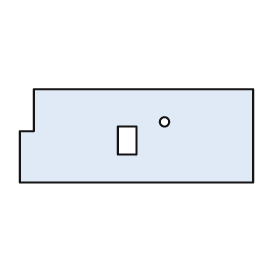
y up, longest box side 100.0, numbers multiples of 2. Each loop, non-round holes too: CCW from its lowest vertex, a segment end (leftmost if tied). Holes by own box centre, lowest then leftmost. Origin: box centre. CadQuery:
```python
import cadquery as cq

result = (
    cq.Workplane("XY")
    .moveTo(-50.0, -20.0)
    .lineTo(50.0, -20.0)
    .lineTo(50.0, 20.0)
    .lineTo(-44.0, 20.0)
    .lineTo(-44.0, 2.0)
    .lineTo(-50.0, 2.0)
    .close()
    .moveTo(-8.0, -8.0)
    .lineTo(0.0, -8.0)
    .lineTo(0.0, 4.0)
    .lineTo(-8.0, 4.0)
    .close()
    .moveTo(12.0, 6.0)
    .circle(2.0)
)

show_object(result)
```